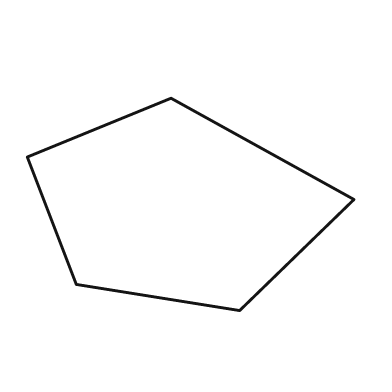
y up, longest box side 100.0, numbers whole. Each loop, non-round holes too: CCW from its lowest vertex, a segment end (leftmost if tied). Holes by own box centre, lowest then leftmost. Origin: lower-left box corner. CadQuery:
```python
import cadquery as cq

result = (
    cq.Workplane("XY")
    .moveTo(65.0, 0.0)
    .lineTo(100.0, 34.0)
    .lineTo(44.0, 65.0)
    .lineTo(0.0, 47.0)
    .lineTo(15.0, 8.0)
    .close()
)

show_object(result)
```